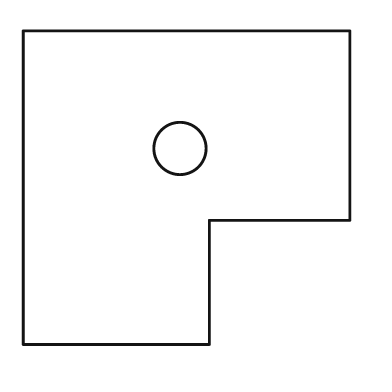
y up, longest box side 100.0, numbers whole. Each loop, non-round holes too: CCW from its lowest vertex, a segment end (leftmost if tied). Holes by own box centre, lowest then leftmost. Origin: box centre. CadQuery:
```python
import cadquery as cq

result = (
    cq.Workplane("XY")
    .moveTo(-50.0, -48.0)
    .lineTo(7.0, -48.0)
    .lineTo(7.0, -10.0)
    .lineTo(50.0, -10.0)
    .lineTo(50.0, 48.0)
    .lineTo(-50.0, 48.0)
    .close()
    .moveTo(-2.0, 12.0)
    .circle(8.0)
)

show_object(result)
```